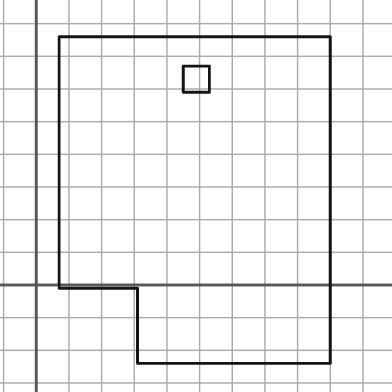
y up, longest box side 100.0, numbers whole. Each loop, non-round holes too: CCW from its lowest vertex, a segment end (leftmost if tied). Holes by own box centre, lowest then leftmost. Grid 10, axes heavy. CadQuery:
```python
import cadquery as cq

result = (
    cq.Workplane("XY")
    .moveTo(31.0, -24.0)
    .lineTo(90.0, -24.0)
    .lineTo(90.0, 76.0)
    .lineTo(7.0, 76.0)
    .lineTo(7.0, -1.0)
    .lineTo(31.0, -1.0)
    .close()
    .moveTo(45.0, 59.0)
    .lineTo(53.0, 59.0)
    .lineTo(53.0, 67.0)
    .lineTo(45.0, 67.0)
    .close()
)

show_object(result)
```